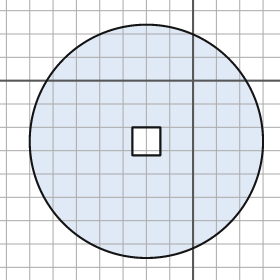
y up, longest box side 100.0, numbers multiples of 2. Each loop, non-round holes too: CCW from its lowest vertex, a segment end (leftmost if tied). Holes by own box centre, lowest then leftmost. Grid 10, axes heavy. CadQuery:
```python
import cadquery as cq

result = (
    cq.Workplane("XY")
    .moveTo(-20.0, -26.0)
    .circle(50.0)
    .moveTo(-26.0, -32.0)
    .lineTo(-14.0, -32.0)
    .lineTo(-14.0, -20.0)
    .lineTo(-26.0, -20.0)
    .close()
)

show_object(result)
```